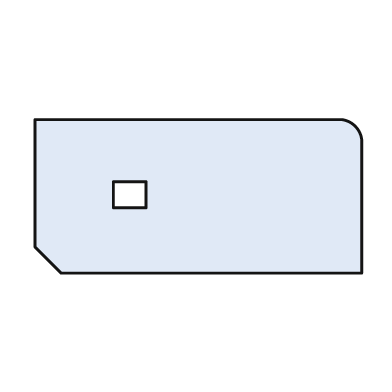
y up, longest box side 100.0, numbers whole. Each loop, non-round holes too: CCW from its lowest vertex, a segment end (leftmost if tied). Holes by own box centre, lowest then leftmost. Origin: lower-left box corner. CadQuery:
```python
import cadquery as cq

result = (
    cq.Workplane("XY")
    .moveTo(8.0, 0.0)
    .lineTo(100.0, 0.0)
    .lineTo(100.0, 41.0)
    .threePointArc((98.0, 45.0), (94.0, 47.0))
    .lineTo(0.0, 47.0)
    .lineTo(0.0, 8.0)
    .close()
    .moveTo(24.0, 20.0)
    .lineTo(34.0, 20.0)
    .lineTo(34.0, 28.0)
    .lineTo(24.0, 28.0)
    .close()
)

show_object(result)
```